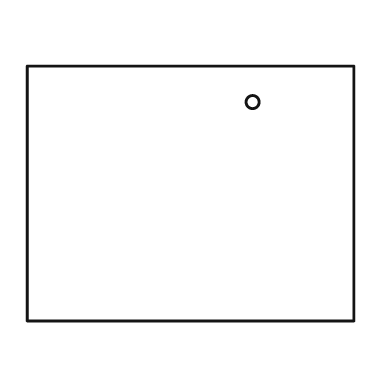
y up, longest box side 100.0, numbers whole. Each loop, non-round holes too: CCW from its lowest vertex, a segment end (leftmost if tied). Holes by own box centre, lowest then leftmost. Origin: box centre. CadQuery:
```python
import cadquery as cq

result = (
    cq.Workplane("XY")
    .moveTo(-50.0, -39.0)
    .lineTo(50.0, -39.0)
    .lineTo(50.0, 39.0)
    .lineTo(-50.0, 39.0)
    .close()
    .moveTo(19.0, 28.0)
    .circle(2.0)
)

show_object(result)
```